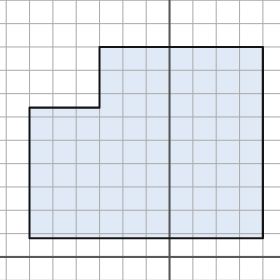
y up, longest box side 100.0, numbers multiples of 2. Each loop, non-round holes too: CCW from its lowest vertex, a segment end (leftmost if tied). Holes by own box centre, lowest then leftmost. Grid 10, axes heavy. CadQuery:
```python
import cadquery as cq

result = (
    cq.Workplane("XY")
    .moveTo(-60.0, 8.0)
    .lineTo(40.0, 8.0)
    .lineTo(40.0, 90.0)
    .lineTo(-30.0, 90.0)
    .lineTo(-30.0, 64.0)
    .lineTo(-60.0, 64.0)
    .close()
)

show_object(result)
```